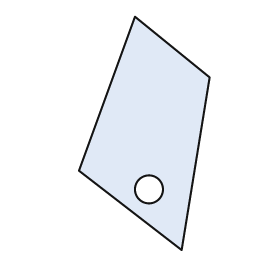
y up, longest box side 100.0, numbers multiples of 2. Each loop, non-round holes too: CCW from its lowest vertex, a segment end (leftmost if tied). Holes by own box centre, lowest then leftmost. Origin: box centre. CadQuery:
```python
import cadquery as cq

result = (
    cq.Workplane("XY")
    .moveTo(16.0, -50.0)
    .lineTo(28.0, 24.0)
    .lineTo(-4.0, 50.0)
    .lineTo(-28.0, -16.0)
    .close()
    .moveTo(2.0, -24.0)
    .circle(6.0)
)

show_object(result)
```